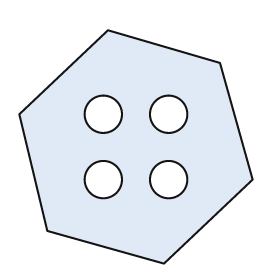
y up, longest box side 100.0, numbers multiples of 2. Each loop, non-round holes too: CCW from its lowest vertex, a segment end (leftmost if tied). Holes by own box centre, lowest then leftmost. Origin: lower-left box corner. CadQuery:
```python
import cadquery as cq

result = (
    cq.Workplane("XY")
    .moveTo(62.0, 0.0)
    .lineTo(100.0, 36.0)
    .lineTo(86.0, 86.0)
    .lineTo(38.0, 100.0)
    .lineTo(0.0, 64.0)
    .lineTo(12.0, 14.0)
    .close()
    .moveTo(36.0, 36.0)
    .circle(8.0)
    .moveTo(64.0, 36.0)
    .circle(8.0)
    .moveTo(36.0, 64.0)
    .circle(8.0)
    .moveTo(64.0, 64.0)
    .circle(8.0)
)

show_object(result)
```